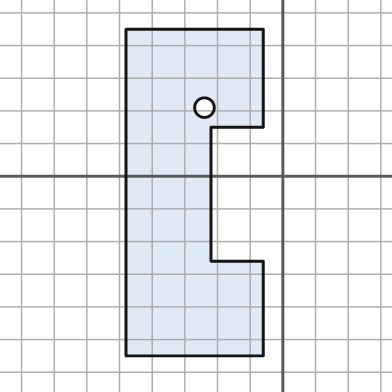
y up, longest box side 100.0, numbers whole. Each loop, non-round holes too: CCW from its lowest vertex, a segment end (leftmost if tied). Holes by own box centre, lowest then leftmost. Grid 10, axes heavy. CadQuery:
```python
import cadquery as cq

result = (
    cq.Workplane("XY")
    .moveTo(-48.0, -55.0)
    .lineTo(-6.0, -55.0)
    .lineTo(-6.0, -26.0)
    .lineTo(-22.0, -26.0)
    .lineTo(-22.0, 15.0)
    .lineTo(-6.0, 15.0)
    .lineTo(-6.0, 45.0)
    .lineTo(-48.0, 45.0)
    .close()
    .moveTo(-24.0, 21.0)
    .circle(3.0)
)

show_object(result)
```